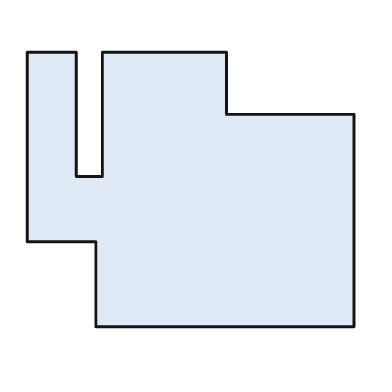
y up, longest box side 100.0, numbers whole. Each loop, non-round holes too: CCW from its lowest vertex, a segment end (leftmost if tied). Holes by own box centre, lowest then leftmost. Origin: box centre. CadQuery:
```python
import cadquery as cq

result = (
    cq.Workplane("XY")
    .moveTo(-29.0, -42.0)
    .lineTo(50.0, -42.0)
    .lineTo(50.0, 23.0)
    .lineTo(11.0, 23.0)
    .lineTo(11.0, 42.0)
    .lineTo(-27.0, 42.0)
    .lineTo(-27.0, 4.0)
    .lineTo(-35.0, 4.0)
    .lineTo(-35.0, 42.0)
    .lineTo(-50.0, 42.0)
    .lineTo(-50.0, -16.0)
    .lineTo(-29.0, -16.0)
    .close()
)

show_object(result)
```